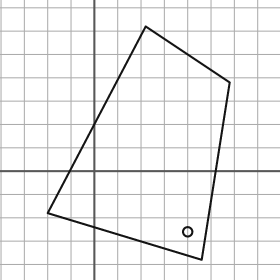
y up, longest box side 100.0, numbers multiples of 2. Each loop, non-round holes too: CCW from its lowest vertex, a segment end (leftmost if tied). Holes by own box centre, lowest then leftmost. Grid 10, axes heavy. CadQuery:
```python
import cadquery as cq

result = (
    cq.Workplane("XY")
    .moveTo(46.0, -38.0)
    .lineTo(58.0, 38.0)
    .lineTo(22.0, 62.0)
    .lineTo(-20.0, -18.0)
    .close()
    .moveTo(40.0, -26.0)
    .circle(2.0)
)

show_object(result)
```